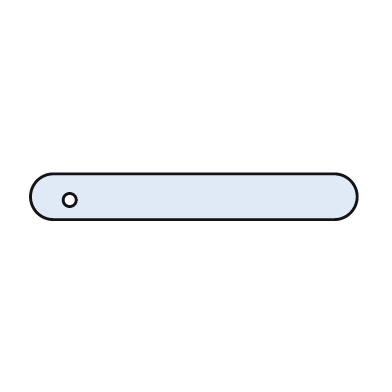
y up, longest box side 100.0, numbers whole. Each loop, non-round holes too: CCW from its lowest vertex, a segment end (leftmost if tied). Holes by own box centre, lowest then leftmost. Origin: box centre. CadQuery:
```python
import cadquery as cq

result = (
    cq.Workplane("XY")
    .moveTo(-43.0, -7.0)
    .lineTo(43.0, -7.0)
    .threePointArc((50.0, 0.0), (43.0, 7.0))
    .lineTo(-43.0, 7.0)
    .threePointArc((-50.0, 0.0), (-43.0, -7.0))
    .close()
    .moveTo(-38.0, -1.0)
    .circle(2.0)
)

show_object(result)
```